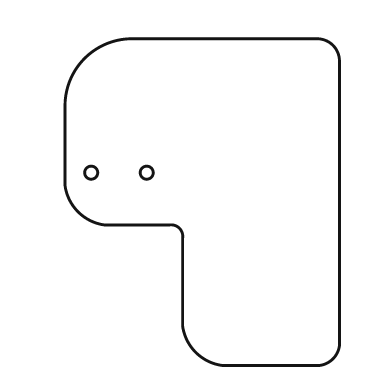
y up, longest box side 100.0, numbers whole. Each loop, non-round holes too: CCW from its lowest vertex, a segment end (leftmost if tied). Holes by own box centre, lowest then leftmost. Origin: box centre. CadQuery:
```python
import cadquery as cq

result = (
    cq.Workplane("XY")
    .moveTo(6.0, -50.0)
    .lineTo(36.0, -50.0)
    .threePointArc((40.0, -48.0), (42.0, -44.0))
    .lineTo(42.0, 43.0)
    .threePointArc((40.0, 48.0), (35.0, 50.0))
    .lineTo(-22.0, 50.0)
    .threePointArc((-36.0, 44.0), (-42.0, 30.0))
    .lineTo(-42.0, 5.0)
    .threePointArc((-38.0, -3.0), (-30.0, -7.0))
    .lineTo(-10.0, -7.0)
    .threePointArc((-7.0, -8.0), (-6.0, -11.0))
    .lineTo(-6.0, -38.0)
    .threePointArc((-2.0, -46.0), (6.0, -50.0))
    .close()
    .moveTo(-34.0, 9.0)
    .circle(2.0)
    .moveTo(-17.0, 9.0)
    .circle(2.0)
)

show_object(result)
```